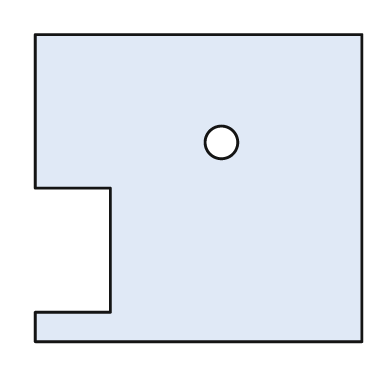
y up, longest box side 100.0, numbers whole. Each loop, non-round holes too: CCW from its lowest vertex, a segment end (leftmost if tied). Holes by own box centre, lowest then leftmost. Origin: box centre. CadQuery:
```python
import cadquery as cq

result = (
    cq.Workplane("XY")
    .moveTo(-50.0, -47.0)
    .lineTo(50.0, -47.0)
    .lineTo(50.0, 47.0)
    .lineTo(-50.0, 47.0)
    .lineTo(-50.0, 0.0)
    .lineTo(-27.0, 0.0)
    .lineTo(-27.0, -38.0)
    .lineTo(-50.0, -38.0)
    .close()
    .moveTo(7.0, 14.0)
    .circle(5.0)
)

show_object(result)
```